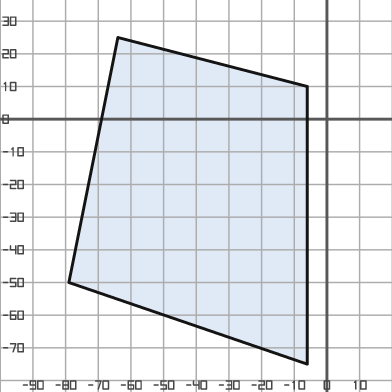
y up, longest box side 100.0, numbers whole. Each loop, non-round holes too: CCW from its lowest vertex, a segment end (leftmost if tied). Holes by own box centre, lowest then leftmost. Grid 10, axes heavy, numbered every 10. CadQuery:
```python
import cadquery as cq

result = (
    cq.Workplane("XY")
    .moveTo(-6.0, -75.0)
    .lineTo(-6.0, 10.0)
    .lineTo(-64.0, 25.0)
    .lineTo(-79.0, -50.0)
    .close()
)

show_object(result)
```